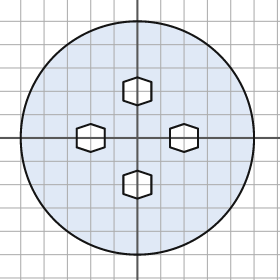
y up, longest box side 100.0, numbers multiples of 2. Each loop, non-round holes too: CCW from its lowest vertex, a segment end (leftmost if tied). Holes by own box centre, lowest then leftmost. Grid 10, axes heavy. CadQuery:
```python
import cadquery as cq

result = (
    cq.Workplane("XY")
    .moveTo(0.0, 0.0)
    .circle(50.0)
    .moveTo(0.0, -26.0)
    .lineTo(6.0, -24.0)
    .lineTo(6.0, -16.0)
    .lineTo(0.0, -14.0)
    .lineTo(-6.0, -16.0)
    .lineTo(-6.0, -24.0)
    .close()
    .moveTo(-20.0, -6.0)
    .lineTo(-14.0, -4.0)
    .lineTo(-14.0, 4.0)
    .lineTo(-20.0, 6.0)
    .lineTo(-26.0, 4.0)
    .lineTo(-26.0, -4.0)
    .close()
    .moveTo(20.0, -6.0)
    .lineTo(26.0, -4.0)
    .lineTo(26.0, 4.0)
    .lineTo(20.0, 6.0)
    .lineTo(14.0, 4.0)
    .lineTo(14.0, -4.0)
    .close()
    .moveTo(0.0, 14.0)
    .lineTo(6.0, 16.0)
    .lineTo(6.0, 24.0)
    .lineTo(0.0, 26.0)
    .lineTo(-6.0, 24.0)
    .lineTo(-6.0, 16.0)
    .close()
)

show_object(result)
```